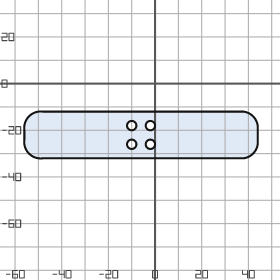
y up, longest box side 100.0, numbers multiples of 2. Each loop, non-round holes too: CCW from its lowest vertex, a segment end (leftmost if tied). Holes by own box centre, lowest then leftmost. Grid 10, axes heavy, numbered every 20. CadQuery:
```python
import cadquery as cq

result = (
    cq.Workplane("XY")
    .moveTo(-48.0, -32.0)
    .lineTo(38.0, -32.0)
    .threePointArc((42.0, -30.0), (44.0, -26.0))
    .lineTo(44.0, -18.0)
    .threePointArc((42.0, -14.0), (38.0, -12.0))
    .lineTo(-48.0, -12.0)
    .threePointArc((-54.0, -14.0), (-56.0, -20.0))
    .lineTo(-56.0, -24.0)
    .threePointArc((-54.0, -30.0), (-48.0, -32.0))
    .close()
    .moveTo(-10.0, -26.0)
    .circle(2.0)
    .moveTo(-2.0, -26.0)
    .circle(2.0)
    .moveTo(-10.0, -18.0)
    .circle(2.0)
    .moveTo(-2.0, -18.0)
    .circle(2.0)
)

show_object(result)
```